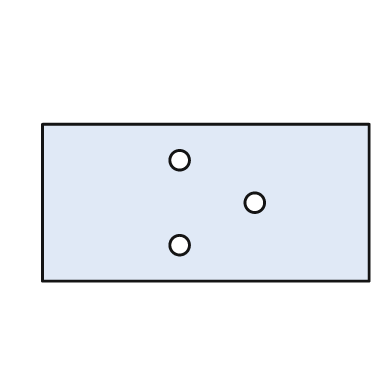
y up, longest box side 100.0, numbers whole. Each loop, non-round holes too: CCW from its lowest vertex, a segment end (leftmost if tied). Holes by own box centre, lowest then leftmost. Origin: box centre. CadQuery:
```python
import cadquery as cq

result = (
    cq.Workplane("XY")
    .moveTo(-50.0, -24.0)
    .lineTo(50.0, -24.0)
    .lineTo(50.0, 24.0)
    .lineTo(-50.0, 24.0)
    .close()
    .moveTo(-8.0, -13.0)
    .circle(3.0)
    .moveTo(15.0, 0.0)
    .circle(3.0)
    .moveTo(-8.0, 13.0)
    .circle(3.0)
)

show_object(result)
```